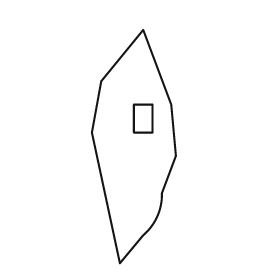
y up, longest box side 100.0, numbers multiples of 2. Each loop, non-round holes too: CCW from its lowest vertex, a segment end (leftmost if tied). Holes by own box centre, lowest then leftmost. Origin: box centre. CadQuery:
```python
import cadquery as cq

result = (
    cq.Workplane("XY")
    .moveTo(-6.0, -50.0)
    .lineTo(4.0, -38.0)
    .threePointArc((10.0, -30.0), (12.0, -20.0))
    .lineTo(18.0, -4.0)
    .lineTo(16.0, 18.0)
    .lineTo(4.0, 50.0)
    .lineTo(-14.0, 28.0)
    .lineTo(-18.0, 6.0)
    .close()
    .moveTo(0.0, 6.0)
    .lineTo(8.0, 6.0)
    .lineTo(8.0, 18.0)
    .lineTo(0.0, 18.0)
    .close()
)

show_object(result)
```